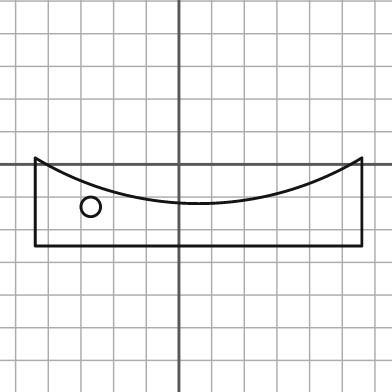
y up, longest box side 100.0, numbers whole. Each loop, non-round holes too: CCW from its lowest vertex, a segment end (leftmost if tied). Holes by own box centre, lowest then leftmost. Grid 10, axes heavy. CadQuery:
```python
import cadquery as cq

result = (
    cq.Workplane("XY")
    .moveTo(-44.0, -25.0)
    .lineTo(56.0, -25.0)
    .lineTo(56.0, 2.0)
    .threePointArc((6.0, -12.0), (-44.0, 2.0))
    .close()
    .moveTo(-27.0, -13.0)
    .circle(3.0)
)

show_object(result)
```